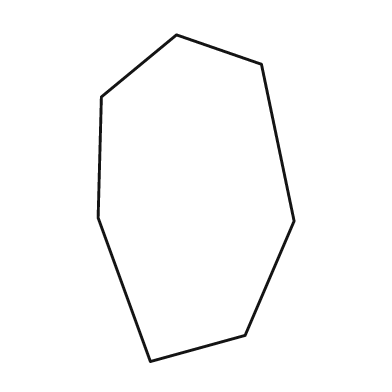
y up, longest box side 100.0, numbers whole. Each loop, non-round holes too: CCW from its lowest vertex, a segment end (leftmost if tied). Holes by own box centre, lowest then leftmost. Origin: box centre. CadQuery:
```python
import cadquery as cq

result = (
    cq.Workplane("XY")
    .moveTo(-14.0, -50.0)
    .lineTo(15.0, -42.0)
    .lineTo(30.0, -7.0)
    .lineTo(20.0, 41.0)
    .lineTo(-6.0, 50.0)
    .lineTo(-29.0, 31.0)
    .lineTo(-30.0, -6.0)
    .close()
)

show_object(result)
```